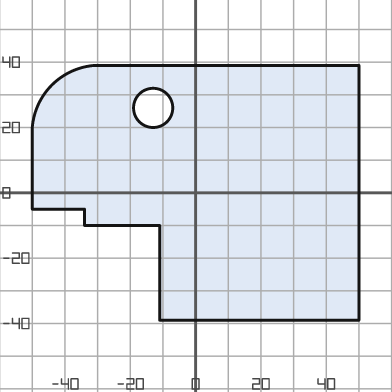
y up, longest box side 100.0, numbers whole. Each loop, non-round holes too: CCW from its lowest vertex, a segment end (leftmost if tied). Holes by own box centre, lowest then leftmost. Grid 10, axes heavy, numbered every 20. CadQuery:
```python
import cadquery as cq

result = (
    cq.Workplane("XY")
    .moveTo(-11.0, -39.0)
    .lineTo(50.0, -39.0)
    .lineTo(50.0, 39.0)
    .lineTo(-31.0, 39.0)
    .threePointArc((-44.0, 33.0), (-50.0, 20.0))
    .lineTo(-50.0, -5.0)
    .lineTo(-34.0, -5.0)
    .lineTo(-34.0, -10.0)
    .lineTo(-11.0, -10.0)
    .close()
    .moveTo(-13.0, 26.0)
    .circle(6.0)
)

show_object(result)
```